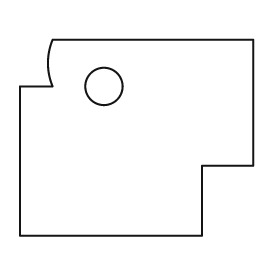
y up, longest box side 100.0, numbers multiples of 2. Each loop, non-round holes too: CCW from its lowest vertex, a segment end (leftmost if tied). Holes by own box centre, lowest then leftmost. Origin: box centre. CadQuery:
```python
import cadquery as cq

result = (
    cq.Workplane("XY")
    .moveTo(-50.0, -42.0)
    .lineTo(28.0, -42.0)
    .lineTo(28.0, -12.0)
    .lineTo(50.0, -12.0)
    .lineTo(50.0, 42.0)
    .lineTo(-36.0, 42.0)
    .threePointArc((-38.0, 32.0), (-36.0, 22.0))
    .lineTo(-50.0, 22.0)
    .close()
    .moveTo(-14.0, 22.0)
    .circle(8.0)
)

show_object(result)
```